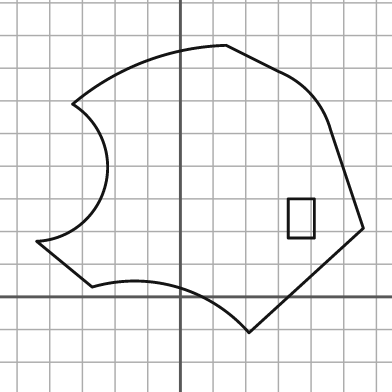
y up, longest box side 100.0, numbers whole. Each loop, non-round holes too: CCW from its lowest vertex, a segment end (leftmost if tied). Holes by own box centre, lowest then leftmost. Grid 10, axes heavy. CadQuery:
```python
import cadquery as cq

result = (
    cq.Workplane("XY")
    .moveTo(21.0, -11.0)
    .lineTo(56.0, 21.0)
    .lineTo(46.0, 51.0)
    .threePointArc((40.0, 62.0), (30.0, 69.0))
    .lineTo(14.0, 77.0)
    .threePointArc((-11.0, 72.0), (-33.0, 59.0))
    .threePointArc((-23.0, 34.0), (-44.0, 17.0))
    .lineTo(-27.0, 3.0)
    .threePointArc((-1.0, 3.0), (21.0, -11.0))
    .close()
    .moveTo(33.0, 18.0)
    .lineTo(41.0, 18.0)
    .lineTo(41.0, 30.0)
    .lineTo(33.0, 30.0)
    .close()
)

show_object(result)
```